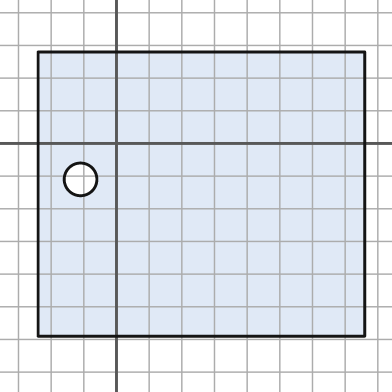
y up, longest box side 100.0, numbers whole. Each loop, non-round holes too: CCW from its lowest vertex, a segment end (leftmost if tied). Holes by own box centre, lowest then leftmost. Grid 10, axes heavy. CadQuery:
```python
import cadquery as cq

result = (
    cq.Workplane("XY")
    .moveTo(-24.0, -59.0)
    .lineTo(76.0, -59.0)
    .lineTo(76.0, 28.0)
    .lineTo(-24.0, 28.0)
    .close()
    .moveTo(-11.0, -11.0)
    .circle(5.0)
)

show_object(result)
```